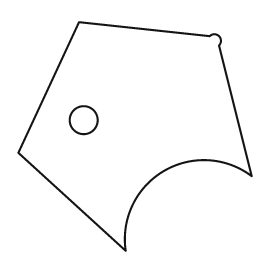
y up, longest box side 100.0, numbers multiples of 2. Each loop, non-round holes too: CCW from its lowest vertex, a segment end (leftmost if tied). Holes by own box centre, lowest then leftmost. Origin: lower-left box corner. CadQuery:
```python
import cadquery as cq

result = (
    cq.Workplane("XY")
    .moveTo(46.0, 0.0)
    .threePointArc((62.0, 34.0), (100.0, 32.0))
    .lineTo(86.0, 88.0)
    .threePointArc((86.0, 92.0), (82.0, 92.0))
    .lineTo(26.0, 98.0)
    .lineTo(0.0, 42.0)
    .close()
    .moveTo(28.0, 56.0)
    .circle(6.0)
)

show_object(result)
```